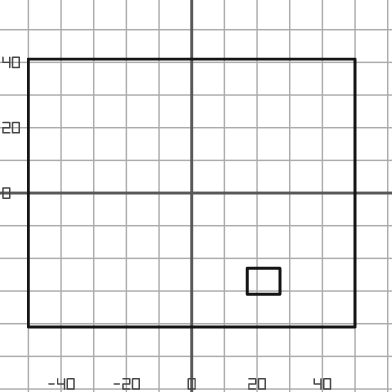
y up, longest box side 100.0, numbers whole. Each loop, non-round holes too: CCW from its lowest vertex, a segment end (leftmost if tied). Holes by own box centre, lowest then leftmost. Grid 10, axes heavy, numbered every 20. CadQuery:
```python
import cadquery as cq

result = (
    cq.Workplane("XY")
    .moveTo(-50.0, -41.0)
    .lineTo(50.0, -41.0)
    .lineTo(50.0, 41.0)
    .lineTo(-50.0, 41.0)
    .close()
    .moveTo(17.0, -31.0)
    .lineTo(27.0, -31.0)
    .lineTo(27.0, -23.0)
    .lineTo(17.0, -23.0)
    .close()
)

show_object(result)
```